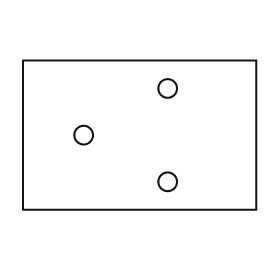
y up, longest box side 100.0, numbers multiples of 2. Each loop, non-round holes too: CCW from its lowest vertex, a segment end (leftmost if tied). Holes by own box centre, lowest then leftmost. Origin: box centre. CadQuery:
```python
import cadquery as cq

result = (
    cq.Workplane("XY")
    .moveTo(-50.0, -32.0)
    .lineTo(50.0, -32.0)
    .lineTo(50.0, 32.0)
    .lineTo(-50.0, 32.0)
    .close()
    .moveTo(12.0, -20.0)
    .circle(4.0)
    .moveTo(-24.0, 0.0)
    .circle(4.0)
    .moveTo(12.0, 20.0)
    .circle(4.0)
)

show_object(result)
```